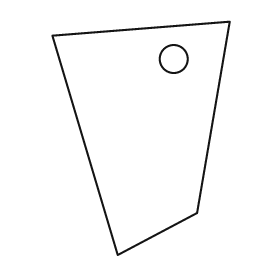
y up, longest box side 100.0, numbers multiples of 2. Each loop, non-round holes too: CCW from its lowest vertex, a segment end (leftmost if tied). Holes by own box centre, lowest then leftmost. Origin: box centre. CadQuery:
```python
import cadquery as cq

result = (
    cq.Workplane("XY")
    .moveTo(-10.0, -50.0)
    .lineTo(24.0, -32.0)
    .lineTo(38.0, 50.0)
    .lineTo(-38.0, 44.0)
    .close()
    .moveTo(14.0, 34.0)
    .circle(6.0)
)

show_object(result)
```